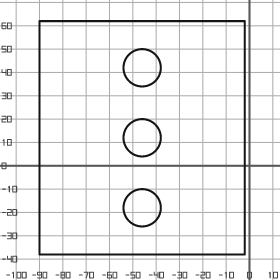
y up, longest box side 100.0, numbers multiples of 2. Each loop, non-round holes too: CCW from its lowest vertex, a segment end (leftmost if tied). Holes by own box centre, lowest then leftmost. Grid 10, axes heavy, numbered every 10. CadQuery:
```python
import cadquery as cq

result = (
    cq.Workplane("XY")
    .moveTo(-90.0, -38.0)
    .lineTo(-2.0, -38.0)
    .lineTo(-2.0, 62.0)
    .lineTo(-90.0, 62.0)
    .close()
    .moveTo(-46.0, -18.0)
    .circle(8.0)
    .moveTo(-46.0, 12.0)
    .circle(8.0)
    .moveTo(-46.0, 42.0)
    .circle(8.0)
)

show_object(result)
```